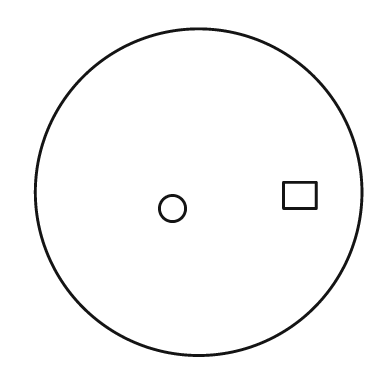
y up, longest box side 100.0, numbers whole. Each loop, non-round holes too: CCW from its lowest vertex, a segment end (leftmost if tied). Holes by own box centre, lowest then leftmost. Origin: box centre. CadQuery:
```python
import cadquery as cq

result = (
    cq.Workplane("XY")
    .moveTo(0.0, 0.0)
    .circle(50.0)
    .moveTo(-8.0, -5.0)
    .circle(4.0)
    .moveTo(26.0, -5.0)
    .lineTo(36.0, -5.0)
    .lineTo(36.0, 3.0)
    .lineTo(26.0, 3.0)
    .close()
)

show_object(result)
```